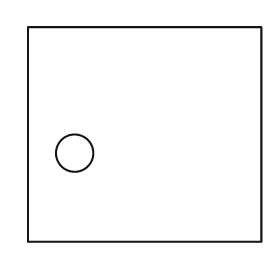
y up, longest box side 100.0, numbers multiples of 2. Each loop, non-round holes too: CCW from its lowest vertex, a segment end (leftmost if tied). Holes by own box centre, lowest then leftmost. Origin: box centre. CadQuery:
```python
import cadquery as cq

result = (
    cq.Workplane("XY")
    .moveTo(-50.0, -46.0)
    .lineTo(50.0, -46.0)
    .lineTo(50.0, 46.0)
    .lineTo(-50.0, 46.0)
    .close()
    .moveTo(-30.0, -8.0)
    .circle(8.0)
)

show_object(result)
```